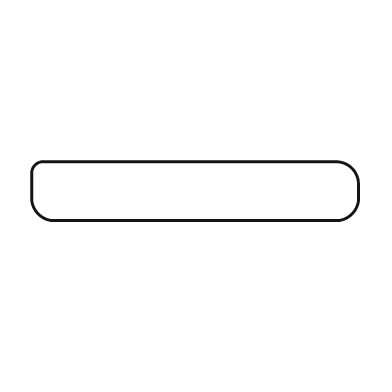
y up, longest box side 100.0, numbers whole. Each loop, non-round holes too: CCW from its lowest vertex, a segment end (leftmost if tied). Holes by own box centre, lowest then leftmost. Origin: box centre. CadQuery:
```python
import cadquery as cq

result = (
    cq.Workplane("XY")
    .moveTo(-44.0, -9.0)
    .lineTo(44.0, -9.0)
    .threePointArc((48.0, -7.0), (50.0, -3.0))
    .lineTo(50.0, 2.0)
    .threePointArc((48.0, 7.0), (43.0, 9.0))
    .lineTo(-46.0, 9.0)
    .threePointArc((-49.0, 8.0), (-50.0, 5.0))
    .lineTo(-50.0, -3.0)
    .threePointArc((-48.0, -7.0), (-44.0, -9.0))
    .close()
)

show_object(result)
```